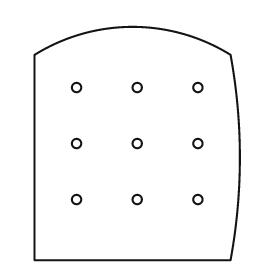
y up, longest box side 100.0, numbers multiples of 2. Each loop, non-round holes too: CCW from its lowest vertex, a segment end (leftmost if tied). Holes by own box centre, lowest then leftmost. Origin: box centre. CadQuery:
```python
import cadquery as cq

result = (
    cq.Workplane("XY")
    .moveTo(-44.0, -50.0)
    .lineTo(40.0, -50.0)
    .threePointArc((44.0, -6.0), (40.0, 38.0))
    .threePointArc((-2.0, 50.0), (-44.0, 38.0))
    .close()
    .moveTo(-26.0, -24.0)
    .circle(2.0)
    .moveTo(0.0, -24.0)
    .circle(2.0)
    .moveTo(26.0, -24.0)
    .circle(2.0)
    .moveTo(-26.0, 0.0)
    .circle(2.0)
    .moveTo(0.0, 0.0)
    .circle(2.0)
    .moveTo(26.0, 0.0)
    .circle(2.0)
    .moveTo(-26.0, 24.0)
    .circle(2.0)
    .moveTo(0.0, 24.0)
    .circle(2.0)
    .moveTo(26.0, 24.0)
    .circle(2.0)
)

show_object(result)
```